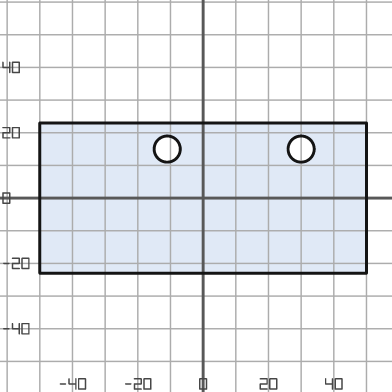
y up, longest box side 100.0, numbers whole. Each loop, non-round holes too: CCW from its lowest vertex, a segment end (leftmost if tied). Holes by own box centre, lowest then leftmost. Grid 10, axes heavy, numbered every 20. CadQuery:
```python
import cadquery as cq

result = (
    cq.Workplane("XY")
    .moveTo(-50.0, -23.0)
    .lineTo(50.0, -23.0)
    .lineTo(50.0, 23.0)
    .lineTo(-50.0, 23.0)
    .close()
    .moveTo(-11.0, 15.0)
    .circle(4.0)
    .moveTo(30.0, 15.0)
    .circle(4.0)
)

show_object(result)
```